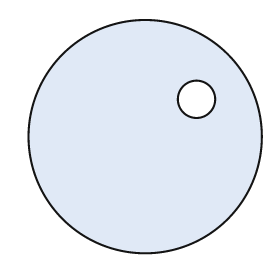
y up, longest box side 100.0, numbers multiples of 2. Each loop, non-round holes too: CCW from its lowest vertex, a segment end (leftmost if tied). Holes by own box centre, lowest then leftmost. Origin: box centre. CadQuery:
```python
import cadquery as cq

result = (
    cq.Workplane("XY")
    .moveTo(0.0, 0.0)
    .circle(50.0)
    .moveTo(22.0, 16.0)
    .circle(8.0)
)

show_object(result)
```